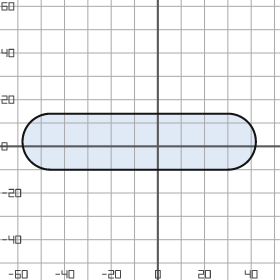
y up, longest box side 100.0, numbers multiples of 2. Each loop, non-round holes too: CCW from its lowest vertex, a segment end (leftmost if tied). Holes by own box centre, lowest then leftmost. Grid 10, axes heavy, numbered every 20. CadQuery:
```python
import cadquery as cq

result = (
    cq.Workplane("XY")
    .moveTo(-46.0, -10.0)
    .lineTo(30.0, -10.0)
    .threePointArc((42.0, 2.0), (30.0, 14.0))
    .lineTo(-46.0, 14.0)
    .threePointArc((-58.0, 2.0), (-46.0, -10.0))
    .close()
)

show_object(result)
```